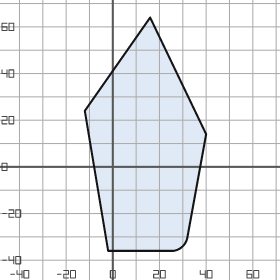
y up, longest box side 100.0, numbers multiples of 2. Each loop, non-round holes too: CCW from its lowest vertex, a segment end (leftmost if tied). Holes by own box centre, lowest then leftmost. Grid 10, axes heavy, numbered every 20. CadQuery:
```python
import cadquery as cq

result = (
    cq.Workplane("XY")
    .moveTo(-2.0, -36.0)
    .lineTo(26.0, -36.0)
    .threePointArc((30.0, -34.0), (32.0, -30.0))
    .lineTo(40.0, 14.0)
    .lineTo(16.0, 64.0)
    .lineTo(-12.0, 24.0)
    .close()
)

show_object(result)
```